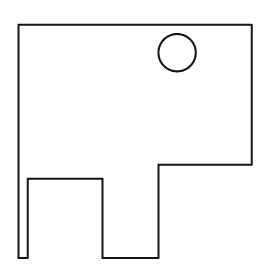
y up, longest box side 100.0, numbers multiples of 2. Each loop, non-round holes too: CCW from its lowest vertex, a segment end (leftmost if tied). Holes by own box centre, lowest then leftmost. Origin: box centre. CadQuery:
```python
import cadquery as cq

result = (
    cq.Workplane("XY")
    .moveTo(-50.0, -50.0)
    .lineTo(-46.0, -50.0)
    .lineTo(-46.0, -16.0)
    .lineTo(-14.0, -16.0)
    .lineTo(-14.0, -50.0)
    .lineTo(10.0, -50.0)
    .lineTo(10.0, -10.0)
    .lineTo(50.0, -10.0)
    .lineTo(50.0, 50.0)
    .lineTo(-50.0, 50.0)
    .close()
    .moveTo(18.0, 38.0)
    .circle(8.0)
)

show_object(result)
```